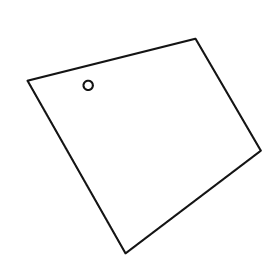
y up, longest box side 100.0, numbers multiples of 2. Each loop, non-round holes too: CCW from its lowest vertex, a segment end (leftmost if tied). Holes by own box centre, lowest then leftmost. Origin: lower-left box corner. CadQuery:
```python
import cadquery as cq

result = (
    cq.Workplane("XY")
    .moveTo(42.0, 0.0)
    .lineTo(100.0, 44.0)
    .lineTo(72.0, 92.0)
    .lineTo(0.0, 74.0)
    .close()
    .moveTo(26.0, 72.0)
    .circle(2.0)
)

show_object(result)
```